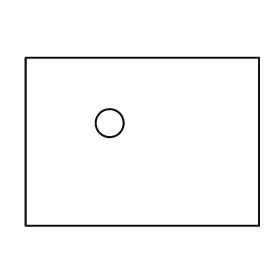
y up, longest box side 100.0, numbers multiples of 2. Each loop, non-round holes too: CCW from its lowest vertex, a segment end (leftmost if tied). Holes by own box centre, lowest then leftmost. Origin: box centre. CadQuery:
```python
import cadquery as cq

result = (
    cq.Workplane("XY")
    .moveTo(-50.0, -36.0)
    .lineTo(50.0, -36.0)
    .lineTo(50.0, 36.0)
    .lineTo(-50.0, 36.0)
    .close()
    .moveTo(-14.0, 8.0)
    .circle(6.0)
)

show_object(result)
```